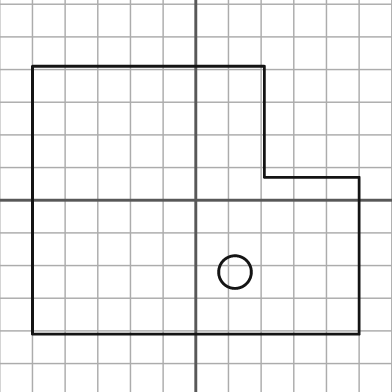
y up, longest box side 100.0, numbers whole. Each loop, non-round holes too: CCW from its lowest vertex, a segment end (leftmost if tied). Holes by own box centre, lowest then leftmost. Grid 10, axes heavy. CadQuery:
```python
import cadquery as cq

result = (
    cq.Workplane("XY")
    .moveTo(-50.0, -41.0)
    .lineTo(50.0, -41.0)
    .lineTo(50.0, 7.0)
    .lineTo(21.0, 7.0)
    .lineTo(21.0, 41.0)
    .lineTo(-50.0, 41.0)
    .close()
    .moveTo(12.0, -22.0)
    .circle(5.0)
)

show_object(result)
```